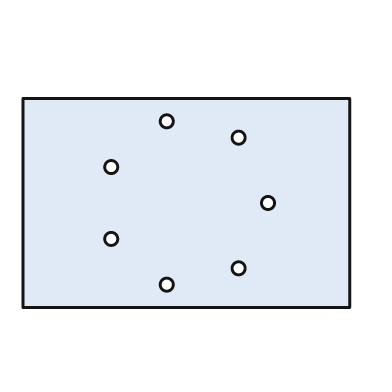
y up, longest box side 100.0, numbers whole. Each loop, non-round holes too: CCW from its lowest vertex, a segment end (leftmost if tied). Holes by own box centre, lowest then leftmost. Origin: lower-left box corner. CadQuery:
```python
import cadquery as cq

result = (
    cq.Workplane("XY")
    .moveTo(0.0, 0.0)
    .lineTo(100.0, 0.0)
    .lineTo(100.0, 64.0)
    .lineTo(0.0, 64.0)
    .close()
    .moveTo(44.0, 7.0)
    .circle(2.0)
    .moveTo(66.0, 12.0)
    .circle(2.0)
    .moveTo(27.0, 21.0)
    .circle(2.0)
    .moveTo(75.0, 32.0)
    .circle(2.0)
    .moveTo(27.0, 43.0)
    .circle(2.0)
    .moveTo(66.0, 52.0)
    .circle(2.0)
    .moveTo(44.0, 57.0)
    .circle(2.0)
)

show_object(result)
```